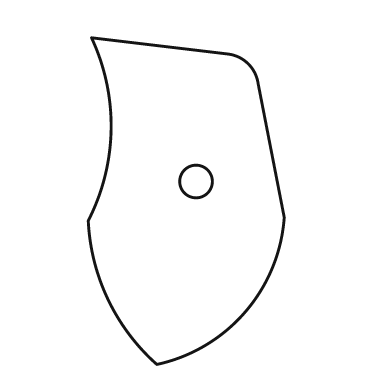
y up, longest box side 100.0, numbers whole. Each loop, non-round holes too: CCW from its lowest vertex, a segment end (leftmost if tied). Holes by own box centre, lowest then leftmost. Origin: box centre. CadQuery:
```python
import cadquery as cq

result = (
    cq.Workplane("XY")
    .moveTo(-9.0, -50.0)
    .threePointArc((18.0, -34.0), (30.0, -5.0))
    .lineTo(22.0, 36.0)
    .threePointArc((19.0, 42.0), (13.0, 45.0))
    .lineTo(-29.0, 50.0)
    .threePointArc((-23.0, 22.0), (-30.0, -6.0))
    .threePointArc((-24.0, -30.0), (-9.0, -50.0))
    .close()
    .moveTo(3.0, 6.0)
    .circle(5.0)
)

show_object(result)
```